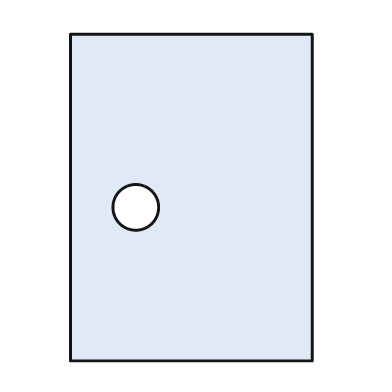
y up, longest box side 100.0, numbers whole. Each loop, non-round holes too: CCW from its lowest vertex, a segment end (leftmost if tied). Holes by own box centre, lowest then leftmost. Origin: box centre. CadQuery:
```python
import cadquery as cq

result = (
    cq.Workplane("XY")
    .moveTo(-37.0, -50.0)
    .lineTo(37.0, -50.0)
    .lineTo(37.0, 50.0)
    .lineTo(-37.0, 50.0)
    .close()
    .moveTo(-17.0, -3.0)
    .circle(7.0)
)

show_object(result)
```